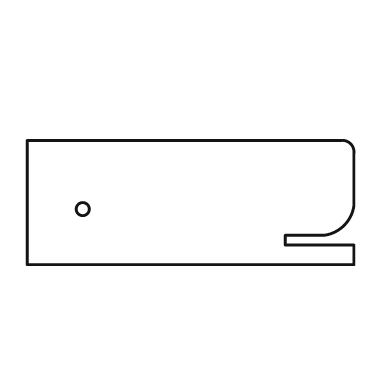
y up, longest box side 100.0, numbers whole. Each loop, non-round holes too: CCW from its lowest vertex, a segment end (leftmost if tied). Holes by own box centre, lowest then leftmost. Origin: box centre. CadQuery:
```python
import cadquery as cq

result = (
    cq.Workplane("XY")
    .moveTo(-50.0, -19.0)
    .lineTo(50.0, -19.0)
    .lineTo(50.0, -13.0)
    .lineTo(29.0, -13.0)
    .lineTo(29.0, -10.0)
    .lineTo(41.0, -10.0)
    .threePointArc((47.0, -7.0), (50.0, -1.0))
    .lineTo(50.0, 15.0)
    .threePointArc((49.0, 18.0), (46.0, 19.0))
    .lineTo(-50.0, 19.0)
    .close()
    .moveTo(-33.0, -2.0)
    .circle(2.0)
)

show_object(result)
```